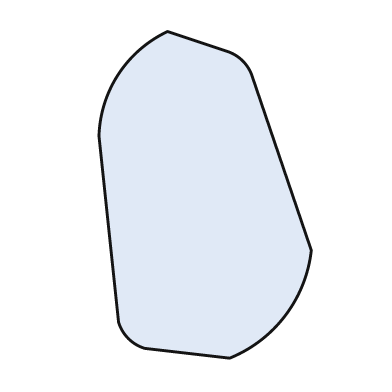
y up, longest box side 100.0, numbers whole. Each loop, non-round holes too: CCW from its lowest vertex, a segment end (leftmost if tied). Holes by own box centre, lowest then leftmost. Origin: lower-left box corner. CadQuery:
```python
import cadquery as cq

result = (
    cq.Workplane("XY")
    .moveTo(40.0, 0.0)
    .threePointArc((57.0, 13.0), (65.0, 33.0))
    .lineTo(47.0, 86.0)
    .threePointArc((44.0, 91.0), (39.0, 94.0))
    .lineTo(21.0, 100.0)
    .threePointArc((6.0, 87.0), (0.0, 68.0))
    .lineTo(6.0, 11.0)
    .threePointArc((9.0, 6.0), (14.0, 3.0))
    .close()
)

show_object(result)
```